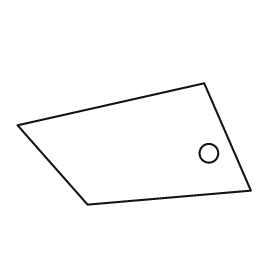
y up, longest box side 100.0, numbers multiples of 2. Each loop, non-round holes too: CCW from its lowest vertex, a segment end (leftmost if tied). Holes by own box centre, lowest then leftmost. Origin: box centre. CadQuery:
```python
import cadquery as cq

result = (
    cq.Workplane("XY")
    .moveTo(-20.0, -26.0)
    .lineTo(50.0, -20.0)
    .lineTo(30.0, 26.0)
    .lineTo(-50.0, 8.0)
    .close()
    .moveTo(32.0, -4.0)
    .circle(4.0)
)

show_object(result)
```